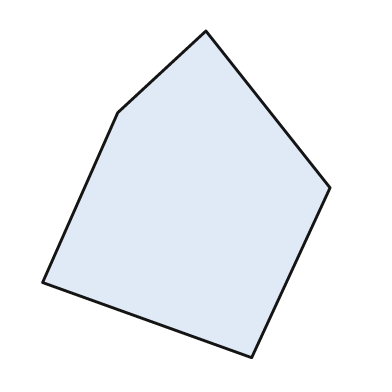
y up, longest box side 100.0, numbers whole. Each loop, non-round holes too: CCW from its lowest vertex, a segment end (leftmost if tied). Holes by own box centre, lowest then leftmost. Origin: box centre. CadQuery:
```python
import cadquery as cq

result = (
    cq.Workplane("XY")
    .moveTo(20.0, -50.0)
    .lineTo(44.0, 2.0)
    .lineTo(6.0, 50.0)
    .lineTo(-21.0, 25.0)
    .lineTo(-44.0, -27.0)
    .close()
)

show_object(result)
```